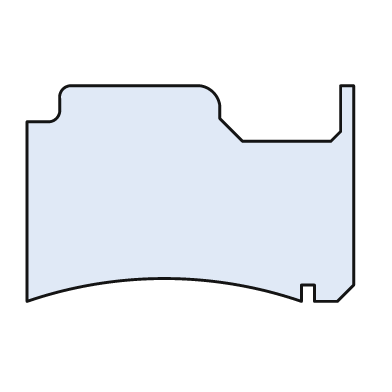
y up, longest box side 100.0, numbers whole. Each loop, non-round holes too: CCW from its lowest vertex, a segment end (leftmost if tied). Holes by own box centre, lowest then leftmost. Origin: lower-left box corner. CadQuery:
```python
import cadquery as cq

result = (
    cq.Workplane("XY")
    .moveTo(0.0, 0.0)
    .threePointArc((42.0, 7.0), (84.0, 0.0))
    .lineTo(84.0, 5.0)
    .lineTo(88.0, 5.0)
    .lineTo(88.0, 0.0)
    .lineTo(95.0, 0.0)
    .lineTo(100.0, 5.0)
    .lineTo(100.0, 66.0)
    .lineTo(96.0, 66.0)
    .lineTo(96.0, 52.0)
    .lineTo(93.0, 49.0)
    .lineTo(66.0, 49.0)
    .lineTo(59.0, 56.0)
    .lineTo(59.0, 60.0)
    .threePointArc((57.0, 64.0), (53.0, 66.0))
    .lineTo(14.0, 66.0)
    .threePointArc((11.0, 65.0), (10.0, 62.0))
    .lineTo(10.0, 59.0)
    .threePointArc((9.0, 56.0), (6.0, 55.0))
    .lineTo(0.0, 55.0)
    .close()
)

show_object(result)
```